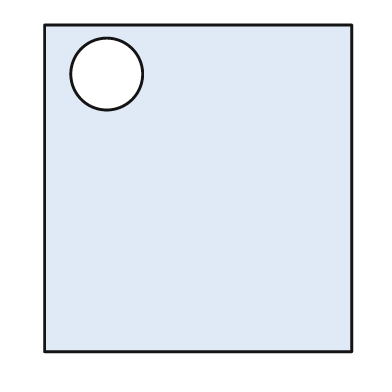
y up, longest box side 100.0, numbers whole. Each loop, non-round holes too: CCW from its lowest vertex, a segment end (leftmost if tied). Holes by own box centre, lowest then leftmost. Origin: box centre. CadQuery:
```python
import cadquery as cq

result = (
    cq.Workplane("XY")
    .moveTo(-47.0, -50.0)
    .lineTo(47.0, -50.0)
    .lineTo(47.0, 50.0)
    .lineTo(-47.0, 50.0)
    .close()
    .moveTo(-28.0, 35.0)
    .circle(11.0)
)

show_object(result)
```